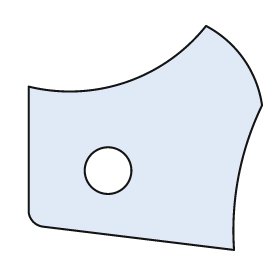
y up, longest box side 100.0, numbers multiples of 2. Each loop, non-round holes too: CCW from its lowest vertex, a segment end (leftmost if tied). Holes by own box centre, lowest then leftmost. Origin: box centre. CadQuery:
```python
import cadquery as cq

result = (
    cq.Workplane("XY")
    .moveTo(38.0, -48.0)
    .threePointArc((40.0, -16.0), (50.0, 14.0))
    .threePointArc((42.0, 34.0), (26.0, 48.0))
    .threePointArc((-8.0, 24.0), (-50.0, 22.0))
    .lineTo(-50.0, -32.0)
    .threePointArc((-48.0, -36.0), (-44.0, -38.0))
    .close()
    .moveTo(-16.0, -14.0)
    .circle(10.0)
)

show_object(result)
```